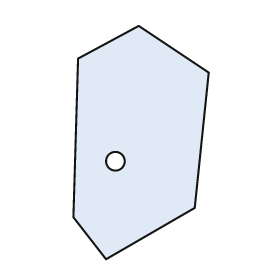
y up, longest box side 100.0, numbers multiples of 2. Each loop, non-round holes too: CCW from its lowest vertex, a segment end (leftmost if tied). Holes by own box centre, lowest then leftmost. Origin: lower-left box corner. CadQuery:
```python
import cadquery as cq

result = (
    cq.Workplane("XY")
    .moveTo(14.0, 0.0)
    .lineTo(52.0, 22.0)
    .lineTo(58.0, 80.0)
    .lineTo(28.0, 100.0)
    .lineTo(2.0, 86.0)
    .lineTo(0.0, 18.0)
    .close()
    .moveTo(18.0, 42.0)
    .circle(4.0)
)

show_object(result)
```